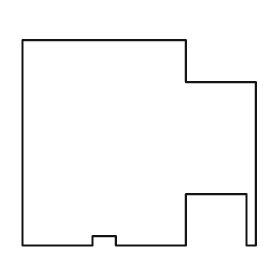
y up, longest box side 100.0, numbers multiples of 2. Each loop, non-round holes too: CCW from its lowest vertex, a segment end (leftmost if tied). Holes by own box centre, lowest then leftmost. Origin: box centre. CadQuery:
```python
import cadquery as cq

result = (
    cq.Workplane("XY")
    .moveTo(-50.0, -44.0)
    .lineTo(-20.0, -44.0)
    .lineTo(-20.0, -40.0)
    .lineTo(-10.0, -40.0)
    .lineTo(-10.0, -44.0)
    .lineTo(20.0, -44.0)
    .lineTo(20.0, -22.0)
    .lineTo(46.0, -22.0)
    .lineTo(46.0, -44.0)
    .lineTo(50.0, -44.0)
    .lineTo(50.0, 26.0)
    .lineTo(20.0, 26.0)
    .lineTo(20.0, 44.0)
    .lineTo(-50.0, 44.0)
    .close()
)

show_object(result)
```